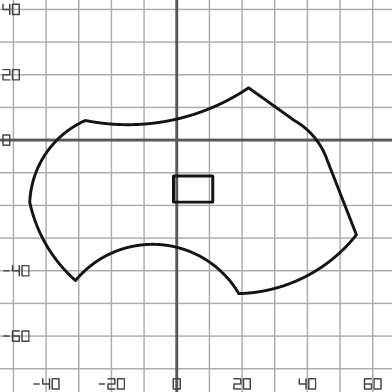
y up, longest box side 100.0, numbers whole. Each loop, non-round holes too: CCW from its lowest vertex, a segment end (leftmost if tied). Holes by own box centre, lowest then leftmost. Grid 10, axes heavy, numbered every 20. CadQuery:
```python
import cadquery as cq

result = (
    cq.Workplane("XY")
    .moveTo(19.0, -47.0)
    .threePointArc((39.0, -42.0), (55.0, -29.0))
    .lineTo(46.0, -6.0)
    .threePointArc((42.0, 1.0), (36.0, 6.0))
    .lineTo(22.0, 16.0)
    .threePointArc((-2.0, 6.0), (-28.0, 6.0))
    .threePointArc((-40.0, -4.0), (-45.0, -19.0))
    .threePointArc((-40.0, -32.0), (-31.0, -43.0))
    .threePointArc((-5.0, -32.0), (19.0, -47.0))
    .close()
    .moveTo(-1.0, -19.0)
    .lineTo(11.0, -19.0)
    .lineTo(11.0, -11.0)
    .lineTo(-1.0, -11.0)
    .close()
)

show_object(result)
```